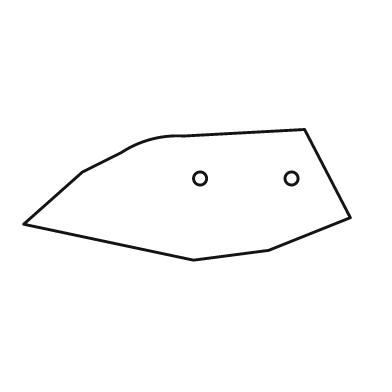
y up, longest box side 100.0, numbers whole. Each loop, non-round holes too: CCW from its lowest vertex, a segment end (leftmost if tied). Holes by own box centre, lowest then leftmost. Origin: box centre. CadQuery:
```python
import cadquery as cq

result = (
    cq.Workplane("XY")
    .moveTo(2.0, -20.0)
    .lineTo(25.0, -17.0)
    .lineTo(50.0, -7.0)
    .lineTo(36.0, 20.0)
    .lineTo(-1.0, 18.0)
    .threePointArc((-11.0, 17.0), (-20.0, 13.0))
    .lineTo(-32.0, 7.0)
    .lineTo(-50.0, -9.0)
    .close()
    .moveTo(4.0, 5.0)
    .circle(2.0)
    .moveTo(32.0, 5.0)
    .circle(2.0)
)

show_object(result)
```